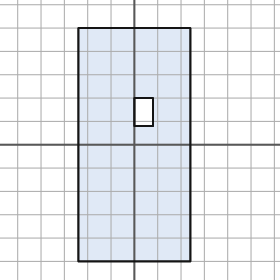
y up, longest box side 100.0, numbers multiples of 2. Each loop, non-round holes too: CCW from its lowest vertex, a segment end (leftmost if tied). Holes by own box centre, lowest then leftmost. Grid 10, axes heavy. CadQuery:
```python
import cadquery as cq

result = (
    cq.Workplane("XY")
    .moveTo(-24.0, -50.0)
    .lineTo(24.0, -50.0)
    .lineTo(24.0, 50.0)
    .lineTo(-24.0, 50.0)
    .close()
    .moveTo(0.0, 8.0)
    .lineTo(8.0, 8.0)
    .lineTo(8.0, 20.0)
    .lineTo(0.0, 20.0)
    .close()
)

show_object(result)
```